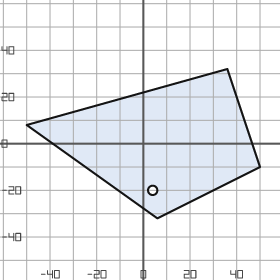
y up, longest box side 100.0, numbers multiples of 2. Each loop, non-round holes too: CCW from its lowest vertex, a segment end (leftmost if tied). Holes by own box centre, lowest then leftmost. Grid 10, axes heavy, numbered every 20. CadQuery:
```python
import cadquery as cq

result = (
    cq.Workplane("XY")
    .moveTo(6.0, -32.0)
    .lineTo(50.0, -10.0)
    .lineTo(36.0, 32.0)
    .lineTo(-50.0, 8.0)
    .close()
    .moveTo(4.0, -20.0)
    .circle(2.0)
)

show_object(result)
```